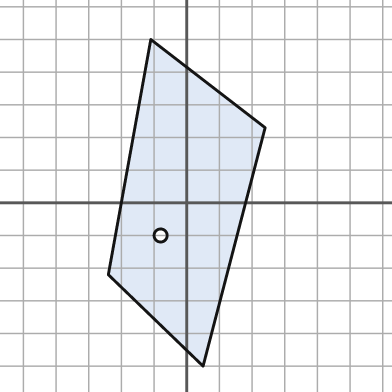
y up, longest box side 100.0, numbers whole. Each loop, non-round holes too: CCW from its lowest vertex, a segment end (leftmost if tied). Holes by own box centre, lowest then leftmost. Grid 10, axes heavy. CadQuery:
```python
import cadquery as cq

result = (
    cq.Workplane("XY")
    .moveTo(5.0, -50.0)
    .lineTo(24.0, 23.0)
    .lineTo(-11.0, 50.0)
    .lineTo(-24.0, -22.0)
    .close()
    .moveTo(-8.0, -10.0)
    .circle(2.0)
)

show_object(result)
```